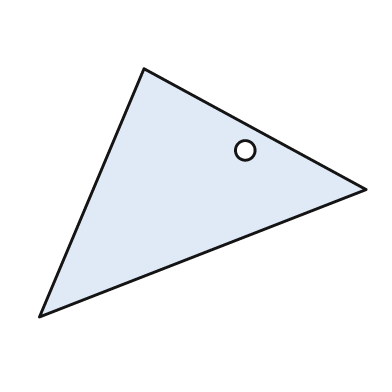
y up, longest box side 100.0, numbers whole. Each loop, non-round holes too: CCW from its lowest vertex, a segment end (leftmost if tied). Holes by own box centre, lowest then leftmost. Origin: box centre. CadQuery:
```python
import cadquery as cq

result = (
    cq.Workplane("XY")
    .moveTo(-50.0, -38.0)
    .lineTo(50.0, 1.0)
    .lineTo(-18.0, 38.0)
    .close()
    .moveTo(13.0, 13.0)
    .circle(3.0)
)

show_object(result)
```